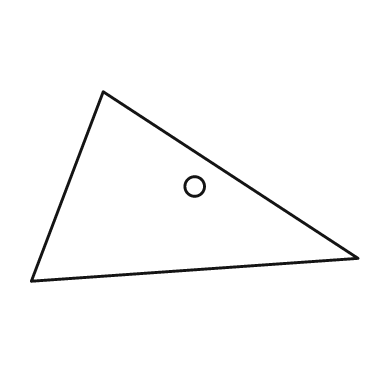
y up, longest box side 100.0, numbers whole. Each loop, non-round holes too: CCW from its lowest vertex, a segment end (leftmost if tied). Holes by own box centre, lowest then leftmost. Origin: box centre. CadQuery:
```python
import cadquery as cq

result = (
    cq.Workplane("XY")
    .moveTo(-50.0, -29.0)
    .lineTo(50.0, -22.0)
    .lineTo(-28.0, 29.0)
    .close()
    .moveTo(0.0, 0.0)
    .circle(3.0)
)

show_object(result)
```